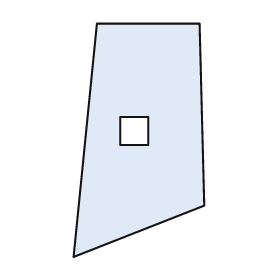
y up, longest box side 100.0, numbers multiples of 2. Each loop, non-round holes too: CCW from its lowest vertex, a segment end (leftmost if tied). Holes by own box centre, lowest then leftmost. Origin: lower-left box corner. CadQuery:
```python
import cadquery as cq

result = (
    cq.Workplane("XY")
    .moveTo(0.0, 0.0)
    .lineTo(56.0, 22.0)
    .lineTo(54.0, 100.0)
    .lineTo(10.0, 100.0)
    .close()
    .moveTo(20.0, 48.0)
    .lineTo(32.0, 48.0)
    .lineTo(32.0, 60.0)
    .lineTo(20.0, 60.0)
    .close()
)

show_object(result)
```